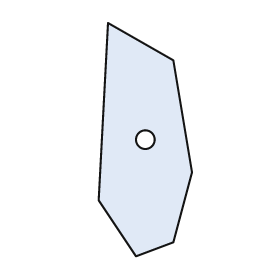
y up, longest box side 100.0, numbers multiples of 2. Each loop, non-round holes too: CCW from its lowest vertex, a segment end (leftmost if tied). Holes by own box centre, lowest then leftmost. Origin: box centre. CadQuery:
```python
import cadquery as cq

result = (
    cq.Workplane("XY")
    .moveTo(-4.0, -50.0)
    .lineTo(12.0, -44.0)
    .lineTo(20.0, -14.0)
    .lineTo(12.0, 34.0)
    .lineTo(-16.0, 50.0)
    .lineTo(-20.0, -26.0)
    .close()
    .moveTo(0.0, 0.0)
    .circle(4.0)
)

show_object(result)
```